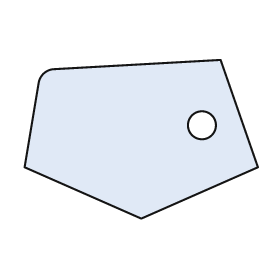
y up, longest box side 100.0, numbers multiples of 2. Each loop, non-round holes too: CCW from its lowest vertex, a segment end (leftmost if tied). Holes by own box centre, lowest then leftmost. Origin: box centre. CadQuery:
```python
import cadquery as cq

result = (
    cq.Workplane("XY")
    .moveTo(0.0, -34.0)
    .lineTo(50.0, -12.0)
    .lineTo(34.0, 34.0)
    .lineTo(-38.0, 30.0)
    .threePointArc((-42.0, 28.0), (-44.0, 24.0))
    .lineTo(-50.0, -12.0)
    .close()
    .moveTo(26.0, 6.0)
    .circle(6.0)
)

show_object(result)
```